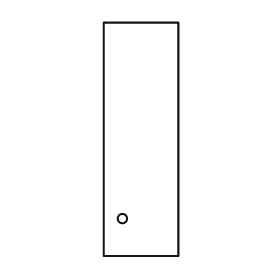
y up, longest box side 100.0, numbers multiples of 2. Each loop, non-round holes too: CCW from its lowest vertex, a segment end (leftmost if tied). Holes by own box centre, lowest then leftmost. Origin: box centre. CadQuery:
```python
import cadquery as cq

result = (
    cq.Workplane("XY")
    .moveTo(-16.0, -50.0)
    .lineTo(16.0, -50.0)
    .lineTo(16.0, 50.0)
    .lineTo(-16.0, 50.0)
    .close()
    .moveTo(-8.0, -34.0)
    .circle(2.0)
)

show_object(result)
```